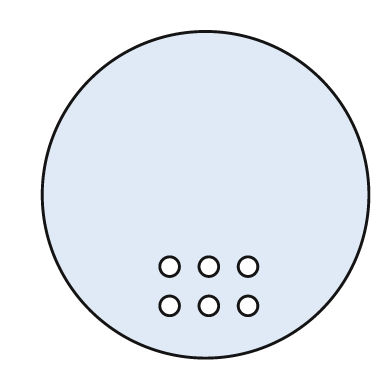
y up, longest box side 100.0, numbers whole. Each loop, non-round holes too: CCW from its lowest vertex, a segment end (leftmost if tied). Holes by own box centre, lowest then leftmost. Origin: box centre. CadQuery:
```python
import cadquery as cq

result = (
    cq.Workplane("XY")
    .moveTo(0.0, 0.0)
    .circle(50.0)
    .moveTo(-11.0, -34.0)
    .circle(3.0)
    .moveTo(1.0, -34.0)
    .circle(3.0)
    .moveTo(13.0, -34.0)
    .circle(3.0)
    .moveTo(-11.0, -22.0)
    .circle(3.0)
    .moveTo(1.0, -22.0)
    .circle(3.0)
    .moveTo(13.0, -22.0)
    .circle(3.0)
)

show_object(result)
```